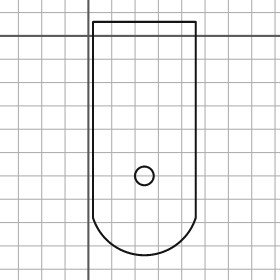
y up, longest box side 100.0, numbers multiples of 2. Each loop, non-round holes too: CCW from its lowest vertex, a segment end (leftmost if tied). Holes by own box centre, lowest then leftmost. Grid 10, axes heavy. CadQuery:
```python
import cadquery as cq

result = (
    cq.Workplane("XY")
    .moveTo(2.0, -78.0)
    .threePointArc((24.0, -94.0), (46.0, -78.0))
    .lineTo(46.0, 6.0)
    .lineTo(2.0, 6.0)
    .close()
    .moveTo(24.0, -60.0)
    .circle(4.0)
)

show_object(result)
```